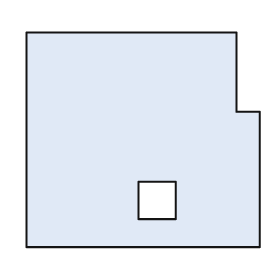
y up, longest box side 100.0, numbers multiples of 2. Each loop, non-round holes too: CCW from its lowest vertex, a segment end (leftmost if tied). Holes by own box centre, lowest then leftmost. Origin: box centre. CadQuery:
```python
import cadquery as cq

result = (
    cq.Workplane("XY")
    .moveTo(-50.0, -46.0)
    .lineTo(50.0, -46.0)
    .lineTo(50.0, 12.0)
    .lineTo(40.0, 12.0)
    .lineTo(40.0, 46.0)
    .lineTo(-50.0, 46.0)
    .close()
    .moveTo(-2.0, -34.0)
    .lineTo(14.0, -34.0)
    .lineTo(14.0, -18.0)
    .lineTo(-2.0, -18.0)
    .close()
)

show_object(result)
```